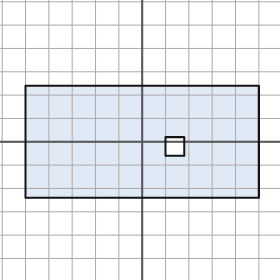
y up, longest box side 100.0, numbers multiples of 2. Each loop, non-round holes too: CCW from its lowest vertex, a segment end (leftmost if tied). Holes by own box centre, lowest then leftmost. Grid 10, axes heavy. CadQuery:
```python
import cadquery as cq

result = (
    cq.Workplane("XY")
    .moveTo(-50.0, -24.0)
    .lineTo(50.0, -24.0)
    .lineTo(50.0, 24.0)
    .lineTo(-50.0, 24.0)
    .close()
    .moveTo(10.0, -6.0)
    .lineTo(18.0, -6.0)
    .lineTo(18.0, 2.0)
    .lineTo(10.0, 2.0)
    .close()
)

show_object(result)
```